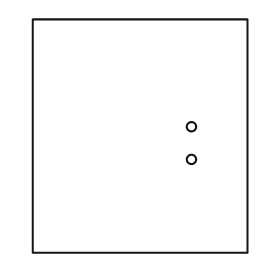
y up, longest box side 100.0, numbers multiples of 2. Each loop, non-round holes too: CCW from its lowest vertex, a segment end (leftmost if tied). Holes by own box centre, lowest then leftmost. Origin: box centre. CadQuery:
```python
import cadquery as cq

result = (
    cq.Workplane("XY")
    .moveTo(-46.0, -50.0)
    .lineTo(46.0, -50.0)
    .lineTo(46.0, 50.0)
    .lineTo(-46.0, 50.0)
    .close()
    .moveTo(22.0, -10.0)
    .circle(2.0)
    .moveTo(22.0, 4.0)
    .circle(2.0)
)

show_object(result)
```